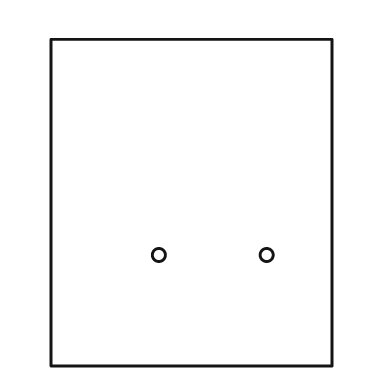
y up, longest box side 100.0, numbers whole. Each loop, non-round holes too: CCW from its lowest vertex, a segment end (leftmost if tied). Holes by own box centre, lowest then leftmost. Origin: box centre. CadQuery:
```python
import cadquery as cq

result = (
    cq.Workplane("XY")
    .moveTo(-43.0, -50.0)
    .lineTo(43.0, -50.0)
    .lineTo(43.0, 50.0)
    .lineTo(-43.0, 50.0)
    .close()
    .moveTo(-10.0, -16.0)
    .circle(2.0)
    .moveTo(23.0, -16.0)
    .circle(2.0)
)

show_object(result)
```